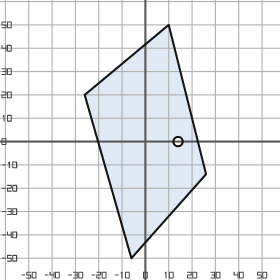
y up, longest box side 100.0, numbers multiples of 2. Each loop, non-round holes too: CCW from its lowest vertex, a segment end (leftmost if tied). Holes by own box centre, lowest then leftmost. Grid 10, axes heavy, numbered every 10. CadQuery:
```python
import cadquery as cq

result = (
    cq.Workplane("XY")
    .moveTo(-6.0, -50.0)
    .lineTo(26.0, -14.0)
    .lineTo(10.0, 50.0)
    .lineTo(-26.0, 20.0)
    .close()
    .moveTo(14.0, 0.0)
    .circle(2.0)
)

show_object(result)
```